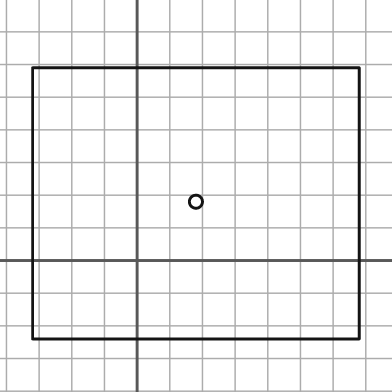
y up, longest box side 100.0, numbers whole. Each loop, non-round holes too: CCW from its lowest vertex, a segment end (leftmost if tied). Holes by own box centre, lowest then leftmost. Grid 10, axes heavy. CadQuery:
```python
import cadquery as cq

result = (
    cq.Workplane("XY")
    .moveTo(-32.0, -24.0)
    .lineTo(68.0, -24.0)
    .lineTo(68.0, 59.0)
    .lineTo(-32.0, 59.0)
    .close()
    .moveTo(18.0, 18.0)
    .circle(2.0)
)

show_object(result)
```